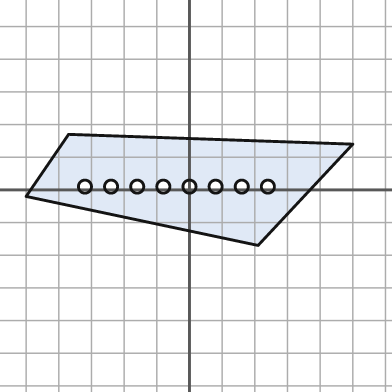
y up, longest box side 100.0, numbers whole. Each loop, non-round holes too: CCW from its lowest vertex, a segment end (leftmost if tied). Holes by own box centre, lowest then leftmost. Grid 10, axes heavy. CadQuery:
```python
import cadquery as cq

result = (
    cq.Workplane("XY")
    .moveTo(21.0, -17.0)
    .lineTo(50.0, 14.0)
    .lineTo(-37.0, 17.0)
    .lineTo(-50.0, -2.0)
    .close()
    .moveTo(-32.0, 1.0)
    .circle(2.0)
    .moveTo(-24.0, 1.0)
    .circle(2.0)
    .moveTo(-16.0, 1.0)
    .circle(2.0)
    .moveTo(-8.0, 1.0)
    .circle(2.0)
    .moveTo(0.0, 1.0)
    .circle(2.0)
    .moveTo(8.0, 1.0)
    .circle(2.0)
    .moveTo(16.0, 1.0)
    .circle(2.0)
    .moveTo(24.0, 1.0)
    .circle(2.0)
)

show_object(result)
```